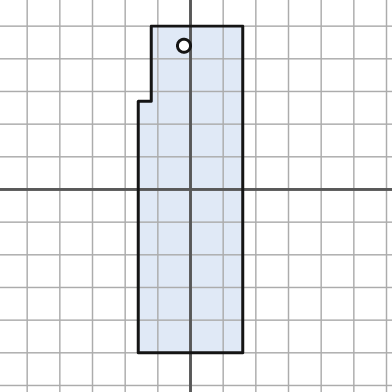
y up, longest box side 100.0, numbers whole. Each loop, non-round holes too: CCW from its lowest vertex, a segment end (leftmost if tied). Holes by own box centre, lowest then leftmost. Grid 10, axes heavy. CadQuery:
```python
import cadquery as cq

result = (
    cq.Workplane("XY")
    .moveTo(-16.0, -50.0)
    .lineTo(16.0, -50.0)
    .lineTo(16.0, 50.0)
    .lineTo(-12.0, 50.0)
    .lineTo(-12.0, 27.0)
    .lineTo(-16.0, 27.0)
    .close()
    .moveTo(-2.0, 44.0)
    .circle(2.0)
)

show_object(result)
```